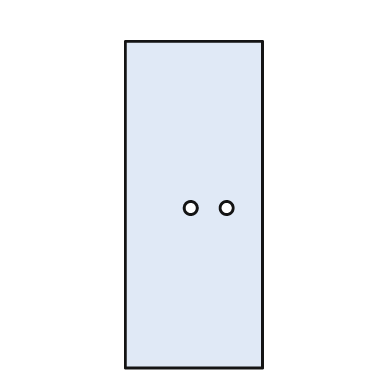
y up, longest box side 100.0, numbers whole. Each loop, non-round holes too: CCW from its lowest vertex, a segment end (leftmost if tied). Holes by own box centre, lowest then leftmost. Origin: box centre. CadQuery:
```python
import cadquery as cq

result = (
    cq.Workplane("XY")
    .moveTo(-21.0, -50.0)
    .lineTo(21.0, -50.0)
    .lineTo(21.0, 50.0)
    .lineTo(-21.0, 50.0)
    .close()
    .moveTo(-1.0, -1.0)
    .circle(2.0)
    .moveTo(10.0, -1.0)
    .circle(2.0)
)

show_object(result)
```